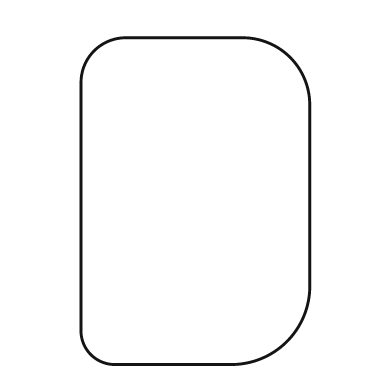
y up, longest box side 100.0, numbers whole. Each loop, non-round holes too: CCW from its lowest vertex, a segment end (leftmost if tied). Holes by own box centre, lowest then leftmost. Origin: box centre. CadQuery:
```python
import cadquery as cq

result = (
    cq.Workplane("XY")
    .moveTo(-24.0, -50.0)
    .lineTo(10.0, -50.0)
    .threePointArc((28.0, -43.0), (35.0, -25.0))
    .lineTo(35.0, 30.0)
    .threePointArc((29.0, 44.0), (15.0, 50.0))
    .lineTo(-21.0, 50.0)
    .threePointArc((-31.0, 46.0), (-35.0, 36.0))
    .lineTo(-35.0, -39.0)
    .threePointArc((-32.0, -47.0), (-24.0, -50.0))
    .close()
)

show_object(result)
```